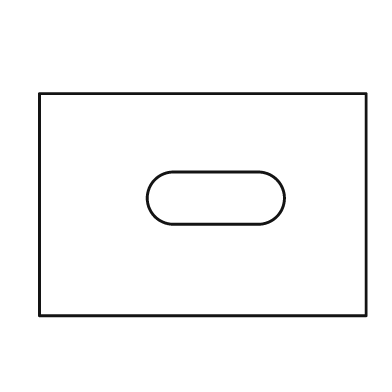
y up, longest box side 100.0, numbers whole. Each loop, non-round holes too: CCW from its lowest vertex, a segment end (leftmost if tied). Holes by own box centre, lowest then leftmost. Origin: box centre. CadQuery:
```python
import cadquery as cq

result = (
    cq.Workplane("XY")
    .moveTo(-50.0, -34.0)
    .lineTo(50.0, -34.0)
    .lineTo(50.0, 34.0)
    .lineTo(-50.0, 34.0)
    .close()
    .moveTo(-9.0, -6.0)
    .lineTo(17.0, -6.0)
    .threePointArc((25.0, 2.0), (17.0, 10.0))
    .lineTo(-9.0, 10.0)
    .threePointArc((-17.0, 2.0), (-9.0, -6.0))
    .close()
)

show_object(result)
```